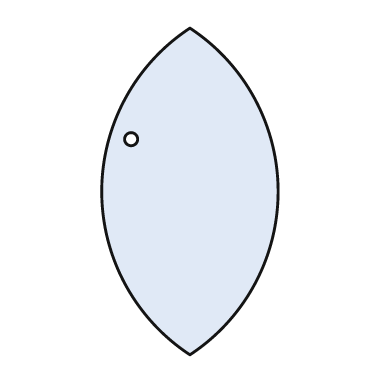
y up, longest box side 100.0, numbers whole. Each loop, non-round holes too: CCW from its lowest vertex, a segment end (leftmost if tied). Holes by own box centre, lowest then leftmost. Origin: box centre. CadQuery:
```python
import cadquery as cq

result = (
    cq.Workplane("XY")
    .moveTo(0.0, -50.0)
    .threePointArc((27.0, 0.0), (0.0, 50.0))
    .threePointArc((-27.0, 0.0), (0.0, -50.0))
    .close()
    .moveTo(-18.0, 16.0)
    .circle(2.0)
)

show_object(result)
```